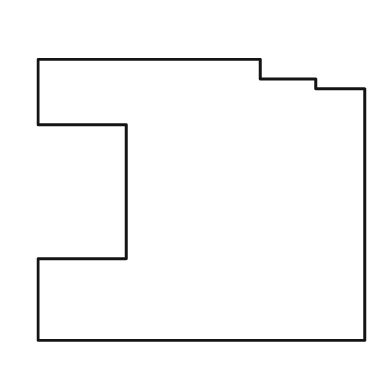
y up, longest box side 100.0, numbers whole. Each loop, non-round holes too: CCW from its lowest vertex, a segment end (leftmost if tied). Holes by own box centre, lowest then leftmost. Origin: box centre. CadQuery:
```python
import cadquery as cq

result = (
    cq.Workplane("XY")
    .moveTo(-50.0, -43.0)
    .lineTo(50.0, -43.0)
    .lineTo(50.0, 34.0)
    .lineTo(35.0, 34.0)
    .lineTo(35.0, 37.0)
    .lineTo(18.0, 37.0)
    .lineTo(18.0, 43.0)
    .lineTo(-50.0, 43.0)
    .lineTo(-50.0, 23.0)
    .lineTo(-23.0, 23.0)
    .lineTo(-23.0, -18.0)
    .lineTo(-50.0, -18.0)
    .close()
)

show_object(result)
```